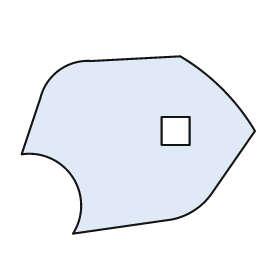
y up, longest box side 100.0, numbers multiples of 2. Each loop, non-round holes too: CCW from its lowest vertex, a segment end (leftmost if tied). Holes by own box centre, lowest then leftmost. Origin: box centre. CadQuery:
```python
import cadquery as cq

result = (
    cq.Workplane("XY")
    .moveTo(-28.0, -38.0)
    .lineTo(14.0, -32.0)
    .threePointArc((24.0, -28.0), (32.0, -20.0))
    .lineTo(50.0, 6.0)
    .threePointArc((36.0, 24.0), (18.0, 38.0))
    .lineTo(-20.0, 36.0)
    .threePointArc((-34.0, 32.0), (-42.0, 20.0))
    .lineTo(-50.0, -4.0)
    .threePointArc((-28.0, -14.0), (-28.0, -38.0))
    .close()
    .moveTo(10.0, 0.0)
    .lineTo(22.0, 0.0)
    .lineTo(22.0, 12.0)
    .lineTo(10.0, 12.0)
    .close()
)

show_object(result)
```